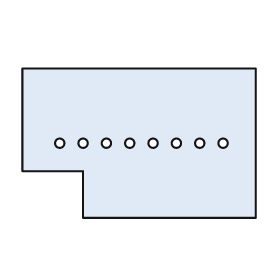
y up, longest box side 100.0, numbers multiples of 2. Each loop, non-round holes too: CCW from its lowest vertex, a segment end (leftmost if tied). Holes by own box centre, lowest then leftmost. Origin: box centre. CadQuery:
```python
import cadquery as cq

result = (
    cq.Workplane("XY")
    .moveTo(-24.0, -32.0)
    .lineTo(50.0, -32.0)
    .lineTo(50.0, 32.0)
    .lineTo(-50.0, 32.0)
    .lineTo(-50.0, -12.0)
    .lineTo(-24.0, -12.0)
    .close()
    .moveTo(-34.0, 0.0)
    .circle(2.0)
    .moveTo(-24.0, 0.0)
    .circle(2.0)
    .moveTo(-14.0, 0.0)
    .circle(2.0)
    .moveTo(-4.0, 0.0)
    .circle(2.0)
    .moveTo(6.0, 0.0)
    .circle(2.0)
    .moveTo(16.0, 0.0)
    .circle(2.0)
    .moveTo(26.0, 0.0)
    .circle(2.0)
    .moveTo(36.0, 0.0)
    .circle(2.0)
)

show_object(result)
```